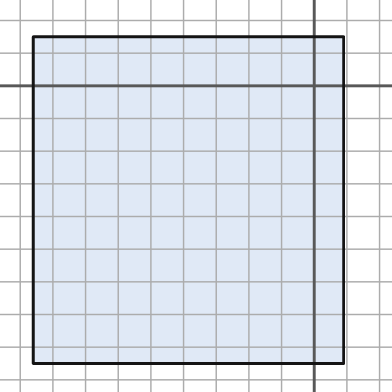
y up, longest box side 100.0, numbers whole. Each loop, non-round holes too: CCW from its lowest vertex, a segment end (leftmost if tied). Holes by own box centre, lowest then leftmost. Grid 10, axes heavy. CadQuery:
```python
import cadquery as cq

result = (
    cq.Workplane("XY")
    .moveTo(-86.0, -85.0)
    .lineTo(9.0, -85.0)
    .lineTo(9.0, 15.0)
    .lineTo(-86.0, 15.0)
    .close()
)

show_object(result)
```